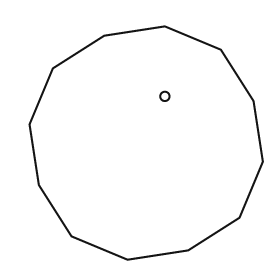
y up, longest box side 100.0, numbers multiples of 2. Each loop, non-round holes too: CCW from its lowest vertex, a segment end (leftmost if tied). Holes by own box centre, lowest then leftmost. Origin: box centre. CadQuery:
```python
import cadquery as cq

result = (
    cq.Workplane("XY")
    .moveTo(-8.0, -50.0)
    .lineTo(18.0, -46.0)
    .lineTo(40.0, -32.0)
    .lineTo(50.0, -8.0)
    .lineTo(46.0, 18.0)
    .lineTo(32.0, 40.0)
    .lineTo(8.0, 50.0)
    .lineTo(-18.0, 46.0)
    .lineTo(-40.0, 32.0)
    .lineTo(-50.0, 8.0)
    .lineTo(-46.0, -18.0)
    .lineTo(-32.0, -40.0)
    .close()
    .moveTo(8.0, 20.0)
    .circle(2.0)
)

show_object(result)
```